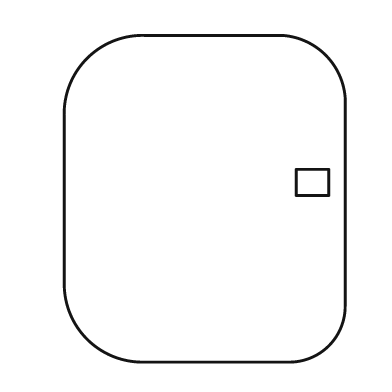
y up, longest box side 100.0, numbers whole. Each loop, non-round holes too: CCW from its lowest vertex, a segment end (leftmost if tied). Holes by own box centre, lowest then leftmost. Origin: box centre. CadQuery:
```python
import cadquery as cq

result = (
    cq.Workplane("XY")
    .moveTo(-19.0, -50.0)
    .lineTo(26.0, -50.0)
    .threePointArc((38.0, -45.0), (43.0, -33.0))
    .lineTo(43.0, 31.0)
    .threePointArc((37.0, 44.0), (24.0, 50.0))
    .lineTo(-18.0, 50.0)
    .threePointArc((-36.0, 43.0), (-43.0, 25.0))
    .lineTo(-43.0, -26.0)
    .threePointArc((-36.0, -43.0), (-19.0, -50.0))
    .close()
    .moveTo(28.0, 1.0)
    .lineTo(38.0, 1.0)
    .lineTo(38.0, 9.0)
    .lineTo(28.0, 9.0)
    .close()
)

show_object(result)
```